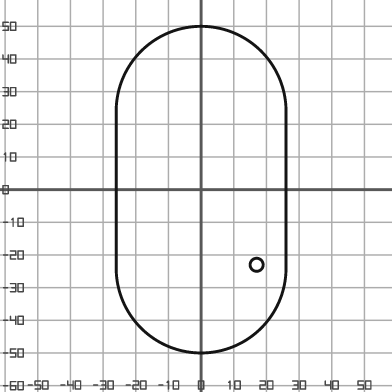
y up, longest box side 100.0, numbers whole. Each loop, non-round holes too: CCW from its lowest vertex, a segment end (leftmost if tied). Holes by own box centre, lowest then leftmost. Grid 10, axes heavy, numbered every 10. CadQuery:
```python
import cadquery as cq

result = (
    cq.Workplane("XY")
    .moveTo(-26.0, -24.0)
    .threePointArc((0.0, -50.0), (26.0, -24.0))
    .lineTo(26.0, 24.0)
    .threePointArc((0.0, 50.0), (-26.0, 24.0))
    .close()
    .moveTo(17.0, -23.0)
    .circle(2.0)
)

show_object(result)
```